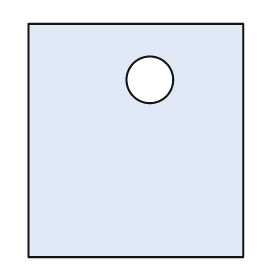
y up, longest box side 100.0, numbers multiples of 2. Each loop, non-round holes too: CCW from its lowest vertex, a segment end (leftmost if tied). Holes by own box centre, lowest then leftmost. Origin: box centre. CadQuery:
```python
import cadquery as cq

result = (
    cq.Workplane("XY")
    .moveTo(-46.0, -50.0)
    .lineTo(46.0, -50.0)
    .lineTo(46.0, 50.0)
    .lineTo(-46.0, 50.0)
    .close()
    .moveTo(6.0, 26.0)
    .circle(10.0)
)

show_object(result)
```